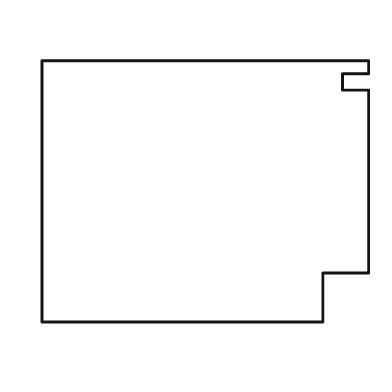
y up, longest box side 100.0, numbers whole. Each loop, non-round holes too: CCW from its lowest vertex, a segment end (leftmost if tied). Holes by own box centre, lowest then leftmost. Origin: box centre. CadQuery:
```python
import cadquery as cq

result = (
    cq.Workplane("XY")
    .moveTo(-50.0, -40.0)
    .lineTo(36.0, -40.0)
    .lineTo(36.0, -25.0)
    .lineTo(50.0, -25.0)
    .lineTo(50.0, 31.0)
    .lineTo(42.0, 31.0)
    .lineTo(42.0, 36.0)
    .lineTo(50.0, 36.0)
    .lineTo(50.0, 40.0)
    .lineTo(-50.0, 40.0)
    .close()
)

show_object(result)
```